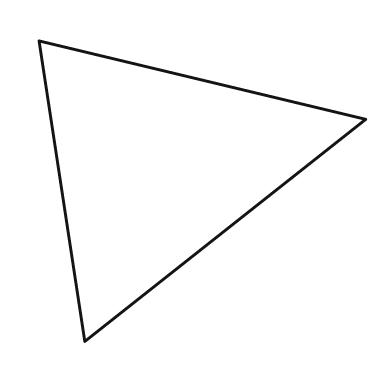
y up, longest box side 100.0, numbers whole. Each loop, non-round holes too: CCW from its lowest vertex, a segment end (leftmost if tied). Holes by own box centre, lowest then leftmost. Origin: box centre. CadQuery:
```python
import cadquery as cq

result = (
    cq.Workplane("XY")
    .moveTo(-36.0, -46.0)
    .lineTo(50.0, 22.0)
    .lineTo(-50.0, 46.0)
    .close()
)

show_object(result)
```